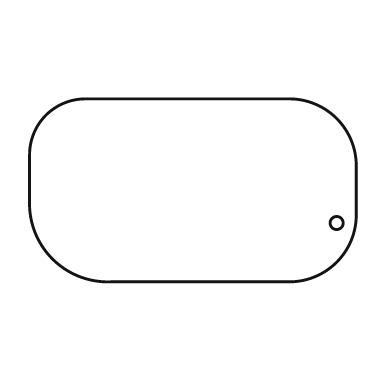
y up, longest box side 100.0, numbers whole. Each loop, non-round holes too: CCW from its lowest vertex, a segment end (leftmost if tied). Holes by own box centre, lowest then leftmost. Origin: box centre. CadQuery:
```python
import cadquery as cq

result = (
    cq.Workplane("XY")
    .moveTo(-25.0, -28.0)
    .lineTo(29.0, -28.0)
    .threePointArc((44.0, -22.0), (50.0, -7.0))
    .lineTo(50.0, 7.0)
    .threePointArc((44.0, 22.0), (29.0, 28.0))
    .lineTo(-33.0, 28.0)
    .threePointArc((-45.0, 23.0), (-50.0, 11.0))
    .lineTo(-50.0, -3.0)
    .threePointArc((-43.0, -21.0), (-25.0, -28.0))
    .close()
    .moveTo(44.0, -10.0)
    .circle(2.0)
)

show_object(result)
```